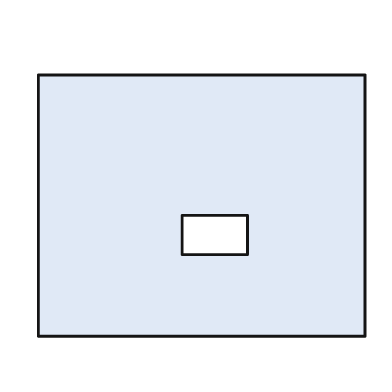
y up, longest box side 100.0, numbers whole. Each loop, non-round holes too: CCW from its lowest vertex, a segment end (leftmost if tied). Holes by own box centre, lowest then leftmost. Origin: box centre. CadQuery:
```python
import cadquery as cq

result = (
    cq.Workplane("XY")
    .moveTo(-50.0, -40.0)
    .lineTo(50.0, -40.0)
    .lineTo(50.0, 40.0)
    .lineTo(-50.0, 40.0)
    .close()
    .moveTo(-6.0, -15.0)
    .lineTo(14.0, -15.0)
    .lineTo(14.0, -3.0)
    .lineTo(-6.0, -3.0)
    .close()
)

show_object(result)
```